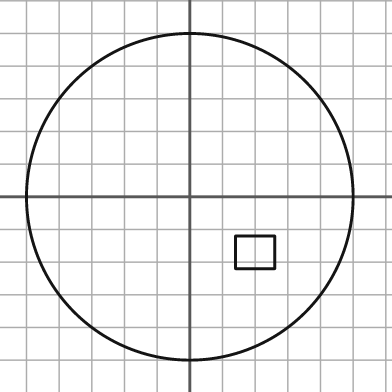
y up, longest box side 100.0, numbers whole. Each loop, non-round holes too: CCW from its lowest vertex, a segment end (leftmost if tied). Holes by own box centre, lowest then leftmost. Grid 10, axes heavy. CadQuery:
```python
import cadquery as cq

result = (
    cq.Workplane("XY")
    .moveTo(0.0, 0.0)
    .circle(50.0)
    .moveTo(14.0, -22.0)
    .lineTo(26.0, -22.0)
    .lineTo(26.0, -12.0)
    .lineTo(14.0, -12.0)
    .close()
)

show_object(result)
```